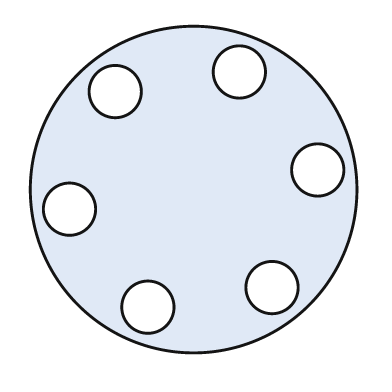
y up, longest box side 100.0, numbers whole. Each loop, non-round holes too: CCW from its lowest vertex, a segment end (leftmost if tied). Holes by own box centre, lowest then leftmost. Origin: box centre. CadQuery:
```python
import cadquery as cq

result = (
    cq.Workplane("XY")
    .moveTo(0.0, 0.0)
    .circle(50.0)
    .moveTo(-14.0, -36.0)
    .circle(8.0)
    .moveTo(24.0, -30.0)
    .circle(8.0)
    .moveTo(-38.0, -6.0)
    .circle(8.0)
    .moveTo(38.0, 6.0)
    .circle(8.0)
    .moveTo(-24.0, 30.0)
    .circle(8.0)
    .moveTo(14.0, 36.0)
    .circle(8.0)
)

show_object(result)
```